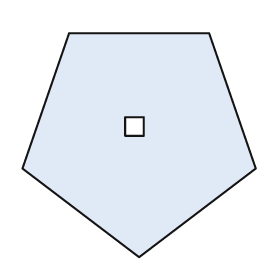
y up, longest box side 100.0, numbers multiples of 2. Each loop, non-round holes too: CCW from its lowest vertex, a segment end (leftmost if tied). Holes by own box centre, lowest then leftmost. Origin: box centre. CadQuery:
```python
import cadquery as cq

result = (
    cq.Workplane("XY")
    .moveTo(0.0, -48.0)
    .lineTo(50.0, -10.0)
    .lineTo(30.0, 48.0)
    .lineTo(-30.0, 48.0)
    .lineTo(-50.0, -10.0)
    .close()
    .moveTo(-6.0, 4.0)
    .lineTo(2.0, 4.0)
    .lineTo(2.0, 12.0)
    .lineTo(-6.0, 12.0)
    .close()
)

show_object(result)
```